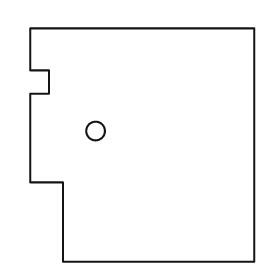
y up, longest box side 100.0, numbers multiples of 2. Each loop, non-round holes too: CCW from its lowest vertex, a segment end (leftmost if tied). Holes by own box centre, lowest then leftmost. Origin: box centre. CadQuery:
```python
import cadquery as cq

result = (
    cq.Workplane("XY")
    .moveTo(-34.0, -50.0)
    .lineTo(48.0, -50.0)
    .lineTo(48.0, 50.0)
    .lineTo(-48.0, 50.0)
    .lineTo(-48.0, 32.0)
    .lineTo(-40.0, 32.0)
    .lineTo(-40.0, 22.0)
    .lineTo(-48.0, 22.0)
    .lineTo(-48.0, -16.0)
    .lineTo(-34.0, -16.0)
    .close()
    .moveTo(-20.0, 6.0)
    .circle(4.0)
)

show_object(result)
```